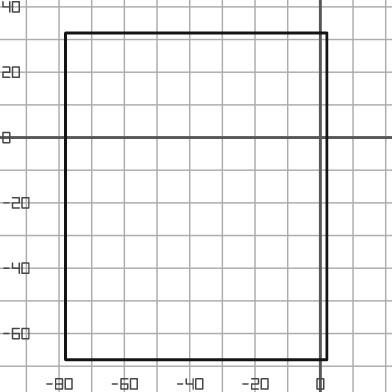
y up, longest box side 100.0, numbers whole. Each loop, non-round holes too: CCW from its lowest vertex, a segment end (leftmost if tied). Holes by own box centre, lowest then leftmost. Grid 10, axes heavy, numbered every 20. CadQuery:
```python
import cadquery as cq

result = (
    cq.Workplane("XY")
    .moveTo(-78.0, -68.0)
    .lineTo(2.0, -68.0)
    .lineTo(2.0, 32.0)
    .lineTo(-78.0, 32.0)
    .close()
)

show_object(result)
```